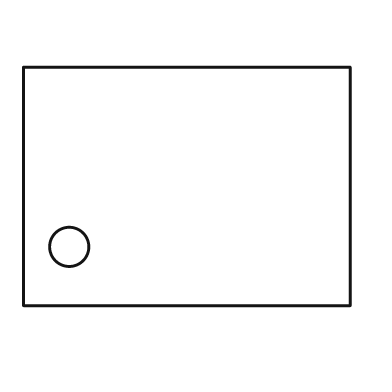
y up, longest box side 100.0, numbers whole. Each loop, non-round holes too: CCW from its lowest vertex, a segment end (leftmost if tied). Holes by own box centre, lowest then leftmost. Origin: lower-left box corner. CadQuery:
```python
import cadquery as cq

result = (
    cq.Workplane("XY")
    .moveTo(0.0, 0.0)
    .lineTo(100.0, 0.0)
    .lineTo(100.0, 73.0)
    .lineTo(0.0, 73.0)
    .close()
    .moveTo(14.0, 18.0)
    .circle(6.0)
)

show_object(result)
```